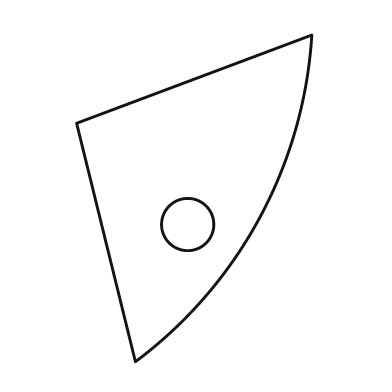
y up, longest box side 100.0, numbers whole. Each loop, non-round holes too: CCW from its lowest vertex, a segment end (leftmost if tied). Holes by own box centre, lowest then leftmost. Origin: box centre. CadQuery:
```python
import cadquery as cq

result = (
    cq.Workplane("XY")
    .moveTo(-18.0, -50.0)
    .threePointArc((20.0, -6.0), (36.0, 50.0))
    .lineTo(-36.0, 23.0)
    .close()
    .moveTo(-2.0, -8.0)
    .circle(8.0)
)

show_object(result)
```